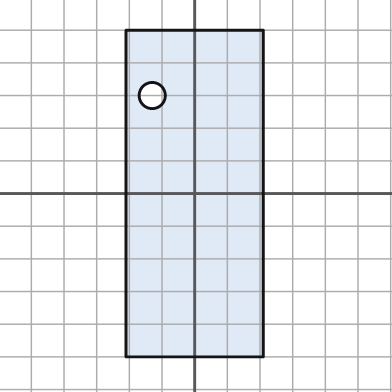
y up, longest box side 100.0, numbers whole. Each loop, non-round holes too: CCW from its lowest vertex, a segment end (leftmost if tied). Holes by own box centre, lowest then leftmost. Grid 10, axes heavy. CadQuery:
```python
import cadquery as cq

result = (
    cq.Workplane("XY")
    .moveTo(-21.0, -50.0)
    .lineTo(21.0, -50.0)
    .lineTo(21.0, 50.0)
    .lineTo(-21.0, 50.0)
    .close()
    .moveTo(-13.0, 30.0)
    .circle(4.0)
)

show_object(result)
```